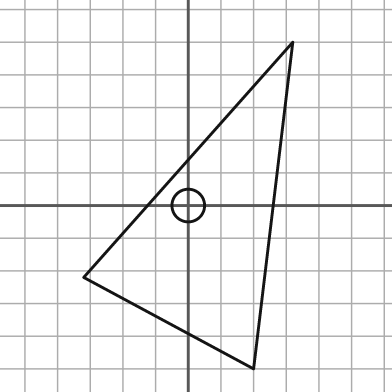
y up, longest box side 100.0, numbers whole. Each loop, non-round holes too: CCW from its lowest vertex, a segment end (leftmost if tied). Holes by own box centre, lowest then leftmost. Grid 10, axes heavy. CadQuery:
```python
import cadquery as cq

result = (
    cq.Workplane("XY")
    .moveTo(20.0, -50.0)
    .lineTo(32.0, 50.0)
    .lineTo(-32.0, -22.0)
    .close()
    .moveTo(0.0, 0.0)
    .circle(5.0)
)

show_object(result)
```